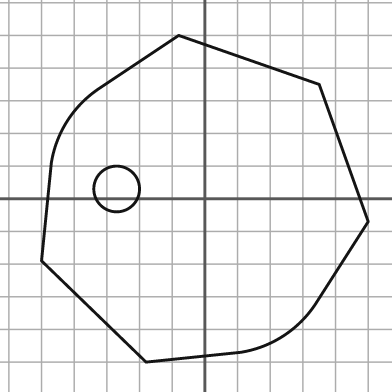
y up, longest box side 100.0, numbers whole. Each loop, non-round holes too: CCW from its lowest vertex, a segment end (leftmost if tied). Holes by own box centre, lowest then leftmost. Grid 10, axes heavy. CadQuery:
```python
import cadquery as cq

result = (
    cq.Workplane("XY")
    .moveTo(-18.0, -50.0)
    .lineTo(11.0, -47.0)
    .threePointArc((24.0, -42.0), (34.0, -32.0))
    .lineTo(50.0, -7.0)
    .lineTo(35.0, 35.0)
    .lineTo(-8.0, 50.0)
    .lineTo(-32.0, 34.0)
    .threePointArc((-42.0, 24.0), (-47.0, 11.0))
    .lineTo(-50.0, -19.0)
    .close()
    .moveTo(-27.0, 3.0)
    .circle(7.0)
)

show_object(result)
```